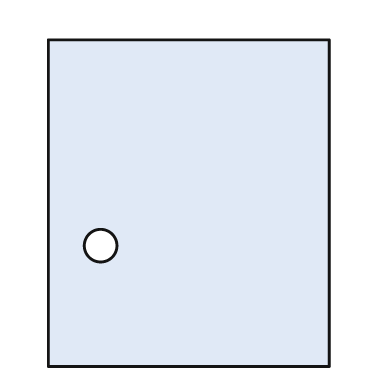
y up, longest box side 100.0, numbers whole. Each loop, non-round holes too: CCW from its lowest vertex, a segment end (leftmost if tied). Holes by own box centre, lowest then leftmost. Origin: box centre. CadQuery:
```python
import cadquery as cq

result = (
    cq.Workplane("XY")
    .moveTo(-43.0, -50.0)
    .lineTo(43.0, -50.0)
    .lineTo(43.0, 50.0)
    .lineTo(-43.0, 50.0)
    .close()
    .moveTo(-27.0, -13.0)
    .circle(5.0)
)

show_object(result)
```